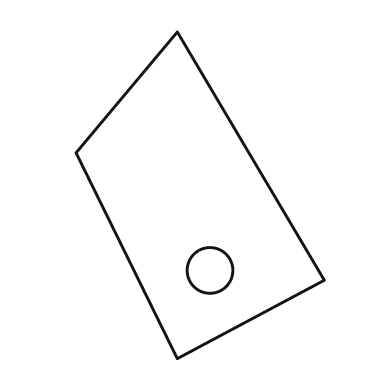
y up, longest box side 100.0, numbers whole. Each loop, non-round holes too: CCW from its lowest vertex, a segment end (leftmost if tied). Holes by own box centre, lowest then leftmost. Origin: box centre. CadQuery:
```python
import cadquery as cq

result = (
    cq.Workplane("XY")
    .moveTo(-7.0, -50.0)
    .lineTo(38.0, -26.0)
    .lineTo(-7.0, 50.0)
    .lineTo(-38.0, 13.0)
    .close()
    .moveTo(3.0, -23.0)
    .circle(7.0)
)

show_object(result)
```